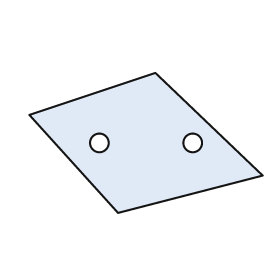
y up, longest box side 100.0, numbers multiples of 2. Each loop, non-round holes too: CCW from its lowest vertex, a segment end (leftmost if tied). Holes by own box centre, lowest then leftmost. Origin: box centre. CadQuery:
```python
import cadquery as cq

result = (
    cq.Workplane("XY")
    .moveTo(-12.0, -30.0)
    .lineTo(50.0, -14.0)
    .lineTo(4.0, 30.0)
    .lineTo(-50.0, 12.0)
    .close()
    .moveTo(-20.0, 0.0)
    .circle(4.0)
    .moveTo(20.0, 0.0)
    .circle(4.0)
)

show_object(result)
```